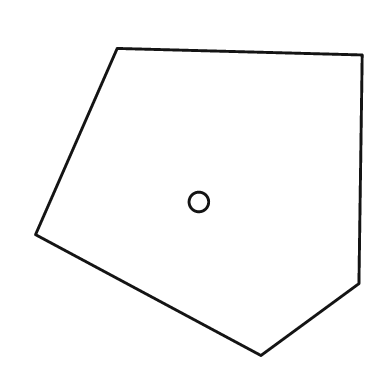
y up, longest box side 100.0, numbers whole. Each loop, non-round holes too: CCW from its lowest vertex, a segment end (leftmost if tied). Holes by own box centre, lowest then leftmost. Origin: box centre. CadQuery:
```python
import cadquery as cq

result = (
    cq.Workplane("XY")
    .moveTo(19.0, -47.0)
    .lineTo(49.0, -25.0)
    .lineTo(50.0, 45.0)
    .lineTo(-25.0, 47.0)
    .lineTo(-50.0, -10.0)
    .close()
    .moveTo(0.0, 0.0)
    .circle(3.0)
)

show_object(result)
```